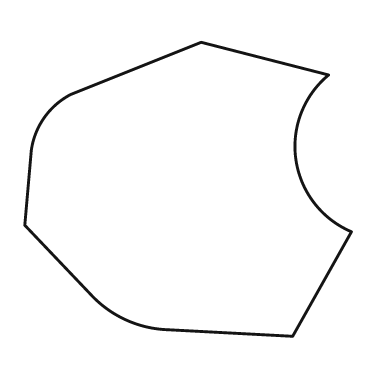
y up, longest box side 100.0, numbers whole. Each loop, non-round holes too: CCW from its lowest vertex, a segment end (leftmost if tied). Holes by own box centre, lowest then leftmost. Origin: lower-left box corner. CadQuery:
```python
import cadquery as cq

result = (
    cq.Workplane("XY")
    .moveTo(82.0, 0.0)
    .lineTo(100.0, 32.0)
    .threePointArc((83.0, 54.0), (93.0, 80.0))
    .lineTo(54.0, 90.0)
    .lineTo(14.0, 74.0)
    .threePointArc((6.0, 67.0), (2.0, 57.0))
    .lineTo(0.0, 34.0)
    .lineTo(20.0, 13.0)
    .threePointArc((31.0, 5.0), (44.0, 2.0))
    .close()
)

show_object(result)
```